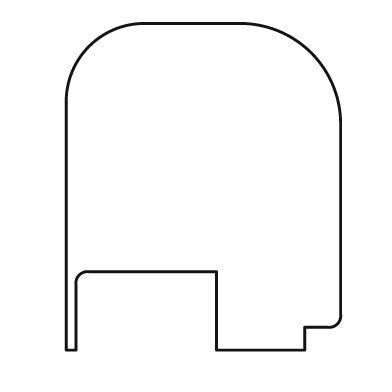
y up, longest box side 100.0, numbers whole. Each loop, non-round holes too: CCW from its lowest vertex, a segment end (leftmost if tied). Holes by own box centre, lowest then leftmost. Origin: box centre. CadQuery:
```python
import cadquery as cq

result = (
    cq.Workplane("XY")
    .moveTo(-42.0, -50.0)
    .lineTo(-39.0, -50.0)
    .lineTo(-39.0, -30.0)
    .threePointArc((-38.0, -27.0), (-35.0, -26.0))
    .lineTo(4.0, -26.0)
    .lineTo(4.0, -50.0)
    .lineTo(31.0, -50.0)
    .lineTo(31.0, -43.0)
    .lineTo(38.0, -43.0)
    .threePointArc((41.0, -42.0), (42.0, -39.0))
    .lineTo(42.0, 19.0)
    .threePointArc((33.0, 41.0), (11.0, 50.0))
    .lineTo(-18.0, 50.0)
    .threePointArc((-35.0, 43.0), (-42.0, 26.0))
    .close()
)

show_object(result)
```